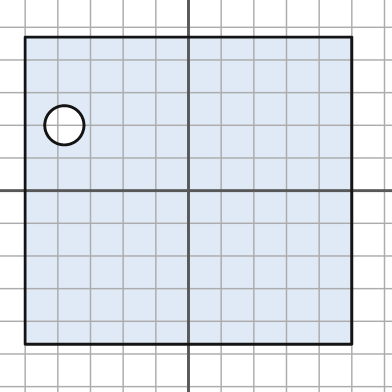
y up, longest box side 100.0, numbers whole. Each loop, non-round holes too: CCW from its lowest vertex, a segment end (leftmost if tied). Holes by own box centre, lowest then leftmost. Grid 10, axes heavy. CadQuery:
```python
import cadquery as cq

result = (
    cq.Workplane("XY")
    .moveTo(-50.0, -47.0)
    .lineTo(50.0, -47.0)
    .lineTo(50.0, 47.0)
    .lineTo(-50.0, 47.0)
    .close()
    .moveTo(-38.0, 20.0)
    .circle(6.0)
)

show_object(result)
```